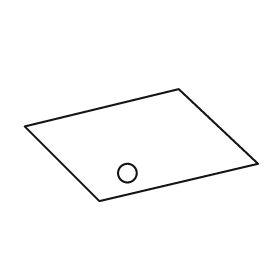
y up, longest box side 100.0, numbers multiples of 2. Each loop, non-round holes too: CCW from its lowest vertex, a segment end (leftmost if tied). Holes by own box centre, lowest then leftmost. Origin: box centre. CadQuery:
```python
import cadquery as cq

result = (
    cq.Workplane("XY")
    .moveTo(-18.0, -24.0)
    .lineTo(50.0, -8.0)
    .lineTo(16.0, 24.0)
    .lineTo(-50.0, 8.0)
    .close()
    .moveTo(-6.0, -12.0)
    .circle(4.0)
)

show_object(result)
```